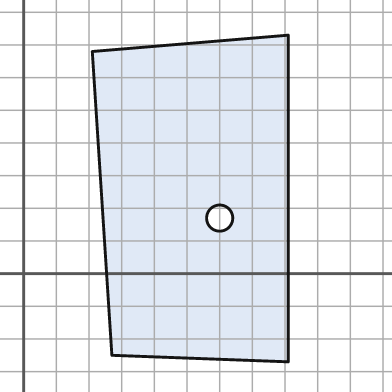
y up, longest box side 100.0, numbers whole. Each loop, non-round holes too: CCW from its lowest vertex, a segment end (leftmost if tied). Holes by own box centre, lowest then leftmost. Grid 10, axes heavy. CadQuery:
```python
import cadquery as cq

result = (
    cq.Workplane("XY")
    .moveTo(81.0, -27.0)
    .lineTo(81.0, 73.0)
    .lineTo(21.0, 68.0)
    .lineTo(27.0, -25.0)
    .close()
    .moveTo(60.0, 17.0)
    .circle(4.0)
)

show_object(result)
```